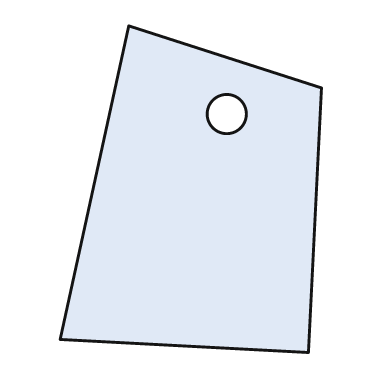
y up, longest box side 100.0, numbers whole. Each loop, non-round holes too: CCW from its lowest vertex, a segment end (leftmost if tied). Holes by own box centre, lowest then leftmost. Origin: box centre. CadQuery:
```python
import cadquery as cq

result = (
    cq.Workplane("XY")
    .moveTo(36.0, -50.0)
    .lineTo(40.0, 31.0)
    .lineTo(-19.0, 50.0)
    .lineTo(-40.0, -46.0)
    .close()
    .moveTo(11.0, 23.0)
    .circle(6.0)
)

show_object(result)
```